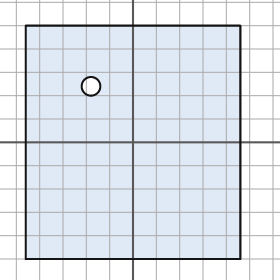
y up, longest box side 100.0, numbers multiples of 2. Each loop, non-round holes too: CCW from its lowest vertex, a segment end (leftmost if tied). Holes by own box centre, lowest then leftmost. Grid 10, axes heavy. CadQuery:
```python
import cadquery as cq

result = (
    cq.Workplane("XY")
    .moveTo(-46.0, -50.0)
    .lineTo(46.0, -50.0)
    .lineTo(46.0, 50.0)
    .lineTo(-46.0, 50.0)
    .close()
    .moveTo(-18.0, 24.0)
    .circle(4.0)
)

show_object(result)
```